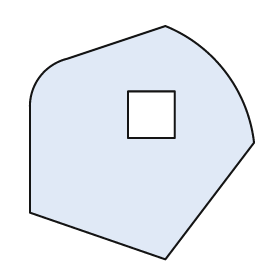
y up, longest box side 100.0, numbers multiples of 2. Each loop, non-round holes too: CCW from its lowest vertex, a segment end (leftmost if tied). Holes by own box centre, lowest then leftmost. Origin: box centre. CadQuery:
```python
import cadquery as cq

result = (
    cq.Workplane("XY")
    .moveTo(10.0, -50.0)
    .lineTo(48.0, 0.0)
    .threePointArc((36.0, 30.0), (10.0, 50.0))
    .lineTo(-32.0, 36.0)
    .threePointArc((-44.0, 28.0), (-48.0, 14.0))
    .lineTo(-48.0, -30.0)
    .close()
    .moveTo(-6.0, 2.0)
    .lineTo(14.0, 2.0)
    .lineTo(14.0, 22.0)
    .lineTo(-6.0, 22.0)
    .close()
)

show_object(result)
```